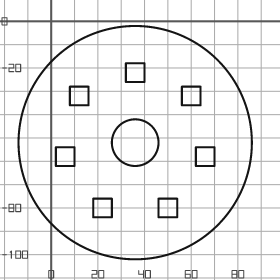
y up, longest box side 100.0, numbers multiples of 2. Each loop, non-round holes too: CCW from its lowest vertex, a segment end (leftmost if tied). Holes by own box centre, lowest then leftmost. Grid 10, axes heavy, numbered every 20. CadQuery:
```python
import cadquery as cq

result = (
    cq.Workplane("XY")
    .moveTo(36.0, -52.0)
    .circle(50.0)
    .moveTo(18.0, -84.0)
    .lineTo(26.0, -84.0)
    .lineTo(26.0, -76.0)
    .lineTo(18.0, -76.0)
    .close()
    .moveTo(46.0, -84.0)
    .lineTo(54.0, -84.0)
    .lineTo(54.0, -76.0)
    .lineTo(46.0, -76.0)
    .close()
    .moveTo(2.0, -62.0)
    .lineTo(10.0, -62.0)
    .lineTo(10.0, -54.0)
    .lineTo(2.0, -54.0)
    .close()
    .moveTo(62.0, -62.0)
    .lineTo(70.0, -62.0)
    .lineTo(70.0, -54.0)
    .lineTo(62.0, -54.0)
    .close()
    .moveTo(36.0, -52.0)
    .circle(10.0)
    .moveTo(8.0, -36.0)
    .lineTo(16.0, -36.0)
    .lineTo(16.0, -28.0)
    .lineTo(8.0, -28.0)
    .close()
    .moveTo(56.0, -36.0)
    .lineTo(64.0, -36.0)
    .lineTo(64.0, -28.0)
    .lineTo(56.0, -28.0)
    .close()
    .moveTo(32.0, -26.0)
    .lineTo(40.0, -26.0)
    .lineTo(40.0, -18.0)
    .lineTo(32.0, -18.0)
    .close()
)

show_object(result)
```